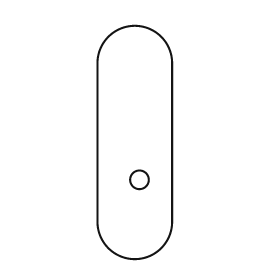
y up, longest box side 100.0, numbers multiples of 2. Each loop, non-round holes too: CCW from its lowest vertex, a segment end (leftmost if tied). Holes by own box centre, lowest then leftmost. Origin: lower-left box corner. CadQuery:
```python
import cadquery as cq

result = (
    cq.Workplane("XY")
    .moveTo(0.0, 16.0)
    .threePointArc((16.0, 0.0), (32.0, 16.0))
    .lineTo(32.0, 84.0)
    .threePointArc((16.0, 100.0), (0.0, 84.0))
    .close()
    .moveTo(18.0, 34.0)
    .circle(4.0)
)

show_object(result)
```